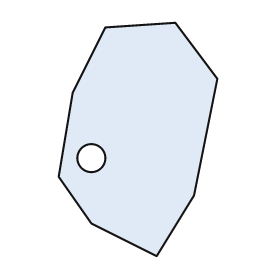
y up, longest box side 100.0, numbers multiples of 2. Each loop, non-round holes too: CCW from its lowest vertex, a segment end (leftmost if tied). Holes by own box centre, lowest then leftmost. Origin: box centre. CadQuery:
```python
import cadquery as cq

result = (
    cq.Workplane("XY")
    .moveTo(8.0, -50.0)
    .lineTo(24.0, -24.0)
    .lineTo(34.0, 26.0)
    .lineTo(16.0, 50.0)
    .lineTo(-14.0, 48.0)
    .lineTo(-28.0, 20.0)
    .lineTo(-34.0, -16.0)
    .lineTo(-20.0, -36.0)
    .close()
    .moveTo(-20.0, -8.0)
    .circle(6.0)
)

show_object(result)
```